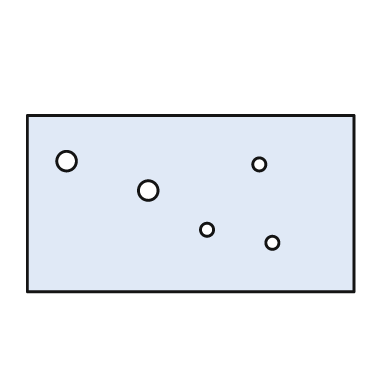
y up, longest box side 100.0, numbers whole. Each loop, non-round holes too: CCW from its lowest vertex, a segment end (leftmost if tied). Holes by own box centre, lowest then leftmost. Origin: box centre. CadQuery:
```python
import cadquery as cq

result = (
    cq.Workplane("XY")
    .moveTo(-50.0, -27.0)
    .lineTo(50.0, -27.0)
    .lineTo(50.0, 27.0)
    .lineTo(-50.0, 27.0)
    .close()
    .moveTo(25.0, -12.0)
    .circle(2.0)
    .moveTo(5.0, -8.0)
    .circle(2.0)
    .moveTo(-13.0, 4.0)
    .circle(3.0)
    .moveTo(21.0, 12.0)
    .circle(2.0)
    .moveTo(-38.0, 13.0)
    .circle(3.0)
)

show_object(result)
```